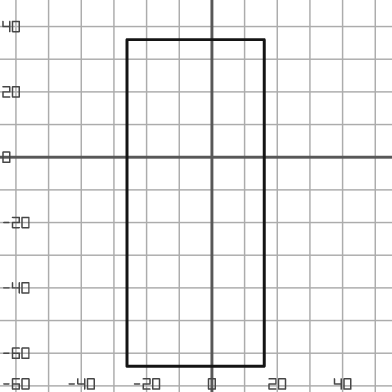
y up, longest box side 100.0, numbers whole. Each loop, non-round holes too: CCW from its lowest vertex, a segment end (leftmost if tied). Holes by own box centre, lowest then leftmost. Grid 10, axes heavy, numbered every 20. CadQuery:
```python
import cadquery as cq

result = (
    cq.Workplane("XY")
    .moveTo(-26.0, -64.0)
    .lineTo(16.0, -64.0)
    .lineTo(16.0, 36.0)
    .lineTo(-26.0, 36.0)
    .close()
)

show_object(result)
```